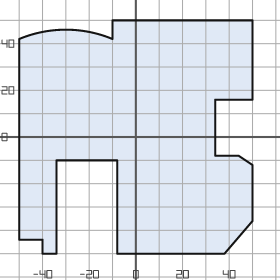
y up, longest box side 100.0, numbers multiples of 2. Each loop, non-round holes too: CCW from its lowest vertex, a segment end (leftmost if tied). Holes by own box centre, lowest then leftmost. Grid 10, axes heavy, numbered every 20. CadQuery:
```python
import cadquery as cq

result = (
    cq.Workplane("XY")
    .moveTo(-40.0, -50.0)
    .lineTo(-34.0, -50.0)
    .lineTo(-34.0, -10.0)
    .lineTo(-8.0, -10.0)
    .lineTo(-8.0, -50.0)
    .lineTo(38.0, -50.0)
    .lineTo(50.0, -36.0)
    .lineTo(50.0, -12.0)
    .lineTo(44.0, -8.0)
    .lineTo(34.0, -8.0)
    .lineTo(34.0, 16.0)
    .lineTo(50.0, 16.0)
    .lineTo(50.0, 50.0)
    .lineTo(-10.0, 50.0)
    .lineTo(-10.0, 42.0)
    .threePointArc((-30.0, 46.0), (-50.0, 42.0))
    .lineTo(-50.0, -44.0)
    .lineTo(-40.0, -44.0)
    .close()
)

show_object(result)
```